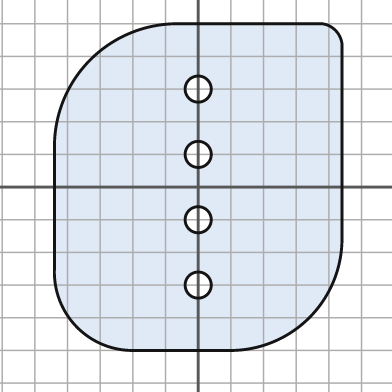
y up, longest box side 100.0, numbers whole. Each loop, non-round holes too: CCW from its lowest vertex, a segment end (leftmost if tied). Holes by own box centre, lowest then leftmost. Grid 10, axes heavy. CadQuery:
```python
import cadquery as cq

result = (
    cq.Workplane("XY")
    .moveTo(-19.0, -50.0)
    .lineTo(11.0, -50.0)
    .threePointArc((34.0, -40.0), (44.0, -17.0))
    .lineTo(44.0, 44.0)
    .threePointArc((42.0, 48.0), (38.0, 50.0))
    .lineTo(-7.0, 50.0)
    .threePointArc((-33.0, 39.0), (-44.0, 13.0))
    .lineTo(-44.0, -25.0)
    .threePointArc((-37.0, -43.0), (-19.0, -50.0))
    .close()
    .moveTo(0.0, -30.0)
    .circle(4.0)
    .moveTo(0.0, -10.0)
    .circle(4.0)
    .moveTo(0.0, 10.0)
    .circle(4.0)
    .moveTo(0.0, 30.0)
    .circle(4.0)
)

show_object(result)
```